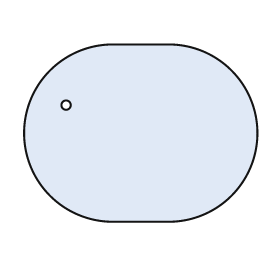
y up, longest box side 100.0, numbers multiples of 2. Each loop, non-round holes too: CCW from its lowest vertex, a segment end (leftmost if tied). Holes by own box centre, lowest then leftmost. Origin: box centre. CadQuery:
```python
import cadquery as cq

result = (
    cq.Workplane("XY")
    .moveTo(-12.0, -38.0)
    .lineTo(12.0, -38.0)
    .threePointArc((50.0, 0.0), (12.0, 38.0))
    .lineTo(-12.0, 38.0)
    .threePointArc((-50.0, 0.0), (-12.0, -38.0))
    .close()
    .moveTo(-32.0, 12.0)
    .circle(2.0)
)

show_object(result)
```